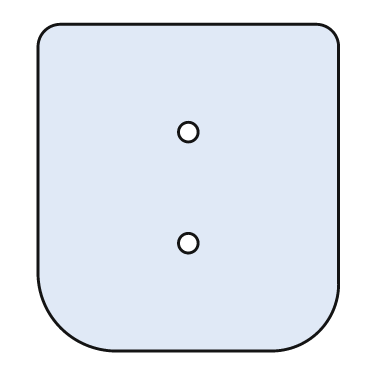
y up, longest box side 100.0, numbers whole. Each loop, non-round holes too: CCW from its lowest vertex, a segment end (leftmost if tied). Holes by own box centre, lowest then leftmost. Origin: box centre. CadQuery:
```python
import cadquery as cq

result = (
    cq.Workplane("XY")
    .moveTo(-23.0, -50.0)
    .lineTo(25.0, -50.0)
    .threePointArc((40.0, -44.0), (46.0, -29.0))
    .lineTo(46.0, 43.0)
    .threePointArc((44.0, 48.0), (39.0, 50.0))
    .lineTo(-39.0, 50.0)
    .threePointArc((-44.0, 48.0), (-46.0, 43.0))
    .lineTo(-46.0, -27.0)
    .threePointArc((-39.0, -43.0), (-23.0, -50.0))
    .close()
    .moveTo(0.0, -17.0)
    .circle(3.0)
    .moveTo(0.0, 17.0)
    .circle(3.0)
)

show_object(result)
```